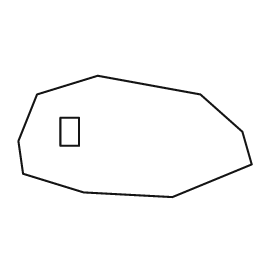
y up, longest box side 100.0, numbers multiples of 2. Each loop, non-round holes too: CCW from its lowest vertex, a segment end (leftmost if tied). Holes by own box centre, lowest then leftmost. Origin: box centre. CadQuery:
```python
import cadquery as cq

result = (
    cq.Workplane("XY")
    .moveTo(16.0, -26.0)
    .lineTo(50.0, -12.0)
    .lineTo(46.0, 2.0)
    .lineTo(28.0, 18.0)
    .lineTo(-16.0, 26.0)
    .lineTo(-42.0, 18.0)
    .lineTo(-50.0, -2.0)
    .lineTo(-48.0, -16.0)
    .lineTo(-22.0, -24.0)
    .close()
    .moveTo(-32.0, -4.0)
    .lineTo(-24.0, -4.0)
    .lineTo(-24.0, 8.0)
    .lineTo(-32.0, 8.0)
    .close()
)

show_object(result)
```